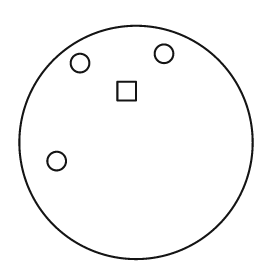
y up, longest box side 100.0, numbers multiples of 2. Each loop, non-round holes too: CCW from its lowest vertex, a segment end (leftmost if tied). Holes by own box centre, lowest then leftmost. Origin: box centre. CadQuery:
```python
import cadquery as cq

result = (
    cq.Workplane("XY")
    .moveTo(0.0, 0.0)
    .circle(50.0)
    .moveTo(-34.0, -8.0)
    .circle(4.0)
    .moveTo(-8.0, 18.0)
    .lineTo(0.0, 18.0)
    .lineTo(0.0, 26.0)
    .lineTo(-8.0, 26.0)
    .close()
    .moveTo(-24.0, 34.0)
    .circle(4.0)
    .moveTo(12.0, 38.0)
    .circle(4.0)
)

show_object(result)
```